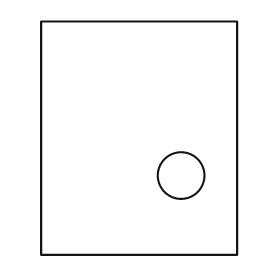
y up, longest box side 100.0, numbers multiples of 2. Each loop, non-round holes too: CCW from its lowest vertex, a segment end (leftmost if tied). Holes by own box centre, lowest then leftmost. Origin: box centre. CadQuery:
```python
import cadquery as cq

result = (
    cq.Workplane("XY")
    .moveTo(-42.0, -50.0)
    .lineTo(42.0, -50.0)
    .lineTo(42.0, 50.0)
    .lineTo(-42.0, 50.0)
    .close()
    .moveTo(18.0, -16.0)
    .circle(10.0)
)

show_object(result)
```